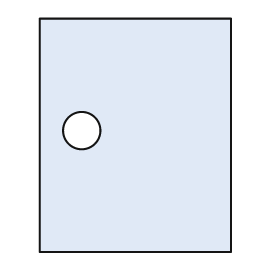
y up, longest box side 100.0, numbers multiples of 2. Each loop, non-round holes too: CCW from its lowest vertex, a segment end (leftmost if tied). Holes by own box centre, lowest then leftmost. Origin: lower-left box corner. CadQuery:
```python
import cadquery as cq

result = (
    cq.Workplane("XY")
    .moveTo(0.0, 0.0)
    .lineTo(82.0, 0.0)
    .lineTo(82.0, 100.0)
    .lineTo(0.0, 100.0)
    .close()
    .moveTo(18.0, 52.0)
    .circle(8.0)
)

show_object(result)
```